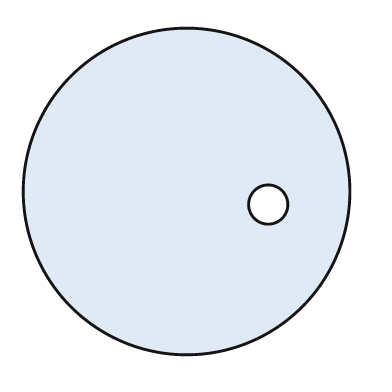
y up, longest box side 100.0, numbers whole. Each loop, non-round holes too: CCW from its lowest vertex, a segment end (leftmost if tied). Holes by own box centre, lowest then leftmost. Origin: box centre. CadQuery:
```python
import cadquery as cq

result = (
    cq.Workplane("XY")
    .moveTo(0.0, 0.0)
    .circle(50.0)
    .moveTo(25.0, -4.0)
    .circle(6.0)
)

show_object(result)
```